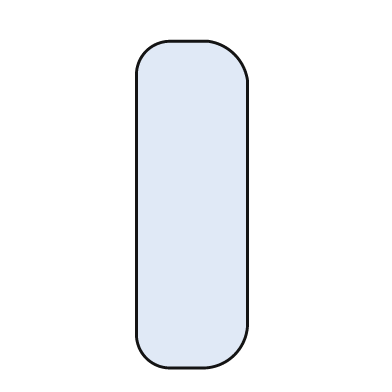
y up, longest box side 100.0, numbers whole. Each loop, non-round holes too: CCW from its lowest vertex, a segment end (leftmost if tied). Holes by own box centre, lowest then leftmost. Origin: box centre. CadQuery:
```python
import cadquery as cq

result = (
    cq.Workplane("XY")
    .moveTo(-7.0, -50.0)
    .lineTo(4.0, -50.0)
    .threePointArc((13.0, -46.0), (17.0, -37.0))
    .lineTo(17.0, 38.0)
    .threePointArc((13.0, 46.0), (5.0, 50.0))
    .lineTo(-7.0, 50.0)
    .threePointArc((-14.0, 47.0), (-17.0, 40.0))
    .lineTo(-17.0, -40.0)
    .threePointArc((-14.0, -47.0), (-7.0, -50.0))
    .close()
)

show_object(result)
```